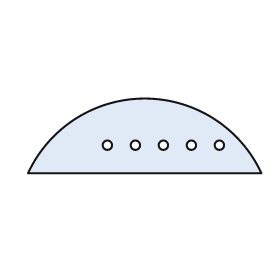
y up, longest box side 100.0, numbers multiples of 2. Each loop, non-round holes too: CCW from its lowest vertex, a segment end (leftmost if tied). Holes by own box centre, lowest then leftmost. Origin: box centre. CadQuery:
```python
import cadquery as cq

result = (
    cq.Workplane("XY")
    .moveTo(-50.0, -16.0)
    .lineTo(50.0, -16.0)
    .threePointArc((0.0, 16.0), (-50.0, -16.0))
    .close()
    .moveTo(-16.0, -4.0)
    .circle(2.0)
    .moveTo(-4.0, -4.0)
    .circle(2.0)
    .moveTo(8.0, -4.0)
    .circle(2.0)
    .moveTo(20.0, -4.0)
    .circle(2.0)
    .moveTo(32.0, -4.0)
    .circle(2.0)
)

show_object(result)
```